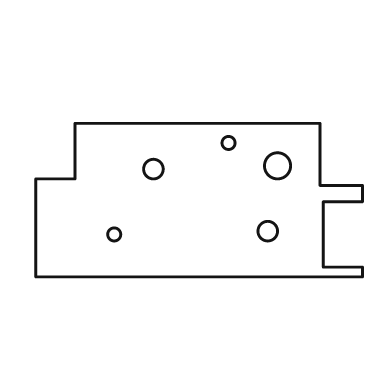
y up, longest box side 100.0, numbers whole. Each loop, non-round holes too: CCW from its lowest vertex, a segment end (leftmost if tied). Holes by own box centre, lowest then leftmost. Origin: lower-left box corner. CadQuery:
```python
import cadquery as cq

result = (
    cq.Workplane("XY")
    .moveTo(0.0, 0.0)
    .lineTo(100.0, 0.0)
    .lineTo(100.0, 3.0)
    .lineTo(88.0, 3.0)
    .lineTo(88.0, 23.0)
    .lineTo(100.0, 23.0)
    .lineTo(100.0, 28.0)
    .lineTo(87.0, 28.0)
    .lineTo(87.0, 47.0)
    .lineTo(12.0, 47.0)
    .lineTo(12.0, 30.0)
    .lineTo(0.0, 30.0)
    .close()
    .moveTo(24.0, 13.0)
    .circle(2.0)
    .moveTo(71.0, 14.0)
    .circle(3.0)
    .moveTo(36.0, 33.0)
    .circle(3.0)
    .moveTo(74.0, 34.0)
    .circle(4.0)
    .moveTo(59.0, 41.0)
    .circle(2.0)
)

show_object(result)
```